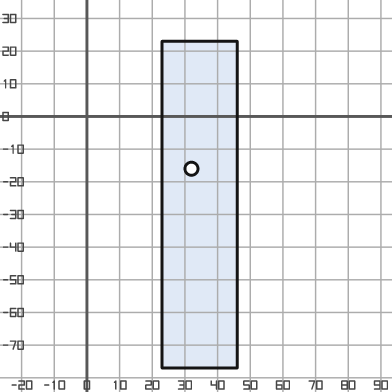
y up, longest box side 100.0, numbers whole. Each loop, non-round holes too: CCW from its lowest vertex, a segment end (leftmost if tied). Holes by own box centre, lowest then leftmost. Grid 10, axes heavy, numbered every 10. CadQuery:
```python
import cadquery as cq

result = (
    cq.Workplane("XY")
    .moveTo(23.0, -77.0)
    .lineTo(46.0, -77.0)
    .lineTo(46.0, 23.0)
    .lineTo(23.0, 23.0)
    .close()
    .moveTo(32.0, -16.0)
    .circle(2.0)
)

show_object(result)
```